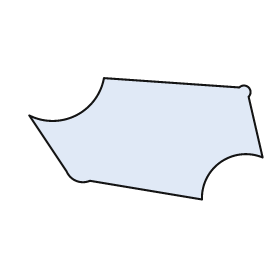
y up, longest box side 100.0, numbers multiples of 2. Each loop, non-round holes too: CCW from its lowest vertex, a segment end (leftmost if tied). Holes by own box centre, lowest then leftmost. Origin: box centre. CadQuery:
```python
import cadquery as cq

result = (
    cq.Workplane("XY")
    .moveTo(24.0, -26.0)
    .threePointArc((32.0, -10.0), (50.0, -8.0))
    .lineTo(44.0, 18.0)
    .threePointArc((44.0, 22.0), (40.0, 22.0))
    .lineTo(-18.0, 26.0)
    .threePointArc((-30.0, 10.0), (-50.0, 10.0))
    .lineTo(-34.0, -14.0)
    .threePointArc((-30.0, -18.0), (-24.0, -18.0))
    .close()
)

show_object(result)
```